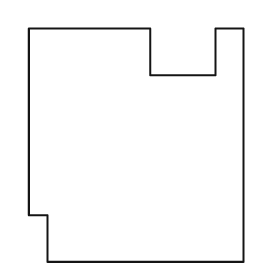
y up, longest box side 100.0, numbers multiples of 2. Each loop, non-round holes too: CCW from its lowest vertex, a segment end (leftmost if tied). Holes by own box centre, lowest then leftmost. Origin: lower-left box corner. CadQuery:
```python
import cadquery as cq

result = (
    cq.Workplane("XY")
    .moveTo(8.0, 0.0)
    .lineTo(92.0, 0.0)
    .lineTo(92.0, 100.0)
    .lineTo(80.0, 100.0)
    .lineTo(80.0, 80.0)
    .lineTo(52.0, 80.0)
    .lineTo(52.0, 100.0)
    .lineTo(0.0, 100.0)
    .lineTo(0.0, 20.0)
    .lineTo(8.0, 20.0)
    .close()
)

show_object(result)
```